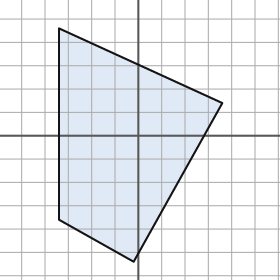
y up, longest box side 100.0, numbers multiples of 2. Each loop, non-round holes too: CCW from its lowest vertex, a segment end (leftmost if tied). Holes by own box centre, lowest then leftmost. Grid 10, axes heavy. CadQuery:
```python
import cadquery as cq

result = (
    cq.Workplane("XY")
    .moveTo(-2.0, -54.0)
    .lineTo(36.0, 14.0)
    .lineTo(-34.0, 46.0)
    .lineTo(-34.0, -36.0)
    .close()
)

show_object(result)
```